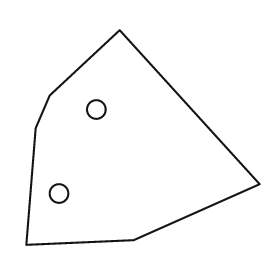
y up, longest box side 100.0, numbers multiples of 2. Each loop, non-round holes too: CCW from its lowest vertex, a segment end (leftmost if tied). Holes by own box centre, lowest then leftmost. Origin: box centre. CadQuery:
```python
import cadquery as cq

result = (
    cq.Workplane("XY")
    .moveTo(-50.0, -46.0)
    .lineTo(-4.0, -44.0)
    .lineTo(50.0, -20.0)
    .lineTo(-10.0, 46.0)
    .lineTo(-40.0, 18.0)
    .lineTo(-46.0, 4.0)
    .close()
    .moveTo(-36.0, -24.0)
    .circle(4.0)
    .moveTo(-20.0, 12.0)
    .circle(4.0)
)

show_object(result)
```